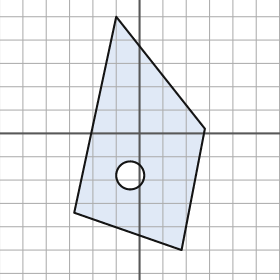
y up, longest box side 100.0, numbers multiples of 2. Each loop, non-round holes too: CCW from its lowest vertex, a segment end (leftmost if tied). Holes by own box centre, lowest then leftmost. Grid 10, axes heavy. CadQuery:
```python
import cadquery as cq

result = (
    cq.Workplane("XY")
    .moveTo(18.0, -50.0)
    .lineTo(28.0, 2.0)
    .lineTo(-10.0, 50.0)
    .lineTo(-28.0, -34.0)
    .close()
    .moveTo(-4.0, -18.0)
    .circle(6.0)
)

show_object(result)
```